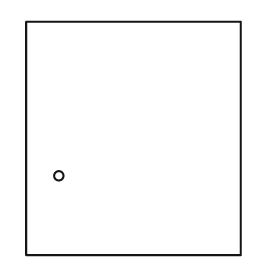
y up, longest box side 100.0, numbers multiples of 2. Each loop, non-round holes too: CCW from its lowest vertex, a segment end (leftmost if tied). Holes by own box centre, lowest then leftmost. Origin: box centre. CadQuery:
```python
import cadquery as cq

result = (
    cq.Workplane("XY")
    .moveTo(-46.0, -50.0)
    .lineTo(46.0, -50.0)
    .lineTo(46.0, 50.0)
    .lineTo(-46.0, 50.0)
    .close()
    .moveTo(-32.0, -16.0)
    .circle(2.0)
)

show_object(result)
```